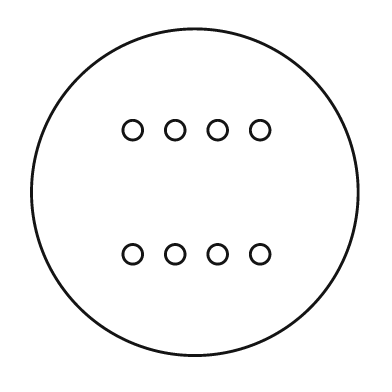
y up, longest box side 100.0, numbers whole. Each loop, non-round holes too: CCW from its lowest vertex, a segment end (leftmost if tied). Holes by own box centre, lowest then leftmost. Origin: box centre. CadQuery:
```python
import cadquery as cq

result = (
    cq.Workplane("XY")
    .moveTo(0.0, 0.0)
    .circle(50.0)
    .moveTo(-19.0, -19.0)
    .circle(3.0)
    .moveTo(-6.0, -19.0)
    .circle(3.0)
    .moveTo(7.0, -19.0)
    .circle(3.0)
    .moveTo(20.0, -19.0)
    .circle(3.0)
    .moveTo(-19.0, 19.0)
    .circle(3.0)
    .moveTo(-6.0, 19.0)
    .circle(3.0)
    .moveTo(7.0, 19.0)
    .circle(3.0)
    .moveTo(20.0, 19.0)
    .circle(3.0)
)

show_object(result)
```